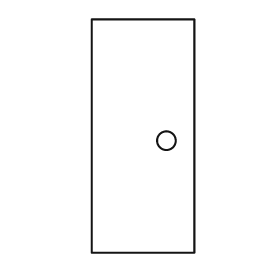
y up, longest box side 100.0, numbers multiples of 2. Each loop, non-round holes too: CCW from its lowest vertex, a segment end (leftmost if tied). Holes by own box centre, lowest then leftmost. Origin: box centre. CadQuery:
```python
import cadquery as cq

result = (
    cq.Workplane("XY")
    .moveTo(-22.0, -50.0)
    .lineTo(22.0, -50.0)
    .lineTo(22.0, 50.0)
    .lineTo(-22.0, 50.0)
    .close()
    .moveTo(10.0, -2.0)
    .circle(4.0)
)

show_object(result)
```